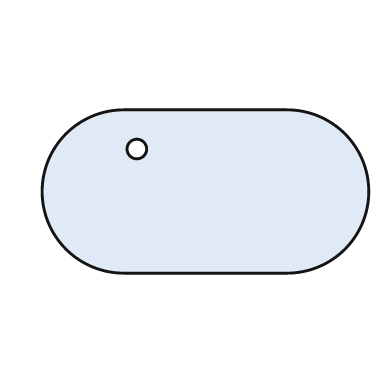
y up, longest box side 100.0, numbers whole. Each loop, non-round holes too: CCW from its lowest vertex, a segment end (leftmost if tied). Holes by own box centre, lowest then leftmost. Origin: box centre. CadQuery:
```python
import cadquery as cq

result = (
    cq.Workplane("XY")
    .moveTo(-25.0, -25.0)
    .lineTo(25.0, -25.0)
    .threePointArc((50.0, 0.0), (25.0, 25.0))
    .lineTo(-25.0, 25.0)
    .threePointArc((-50.0, 0.0), (-25.0, -25.0))
    .close()
    .moveTo(-21.0, 13.0)
    .circle(3.0)
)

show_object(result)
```